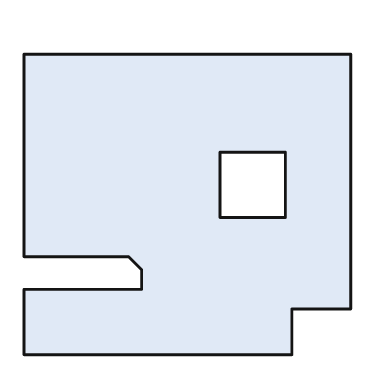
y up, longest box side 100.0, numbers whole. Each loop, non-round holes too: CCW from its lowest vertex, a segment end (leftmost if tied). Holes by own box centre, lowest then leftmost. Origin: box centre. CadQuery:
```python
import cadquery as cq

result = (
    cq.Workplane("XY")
    .moveTo(-50.0, -46.0)
    .lineTo(32.0, -46.0)
    .lineTo(32.0, -32.0)
    .lineTo(50.0, -32.0)
    .lineTo(50.0, 46.0)
    .lineTo(-50.0, 46.0)
    .lineTo(-50.0, -16.0)
    .lineTo(-18.0, -16.0)
    .lineTo(-14.0, -20.0)
    .lineTo(-14.0, -26.0)
    .lineTo(-50.0, -26.0)
    .close()
    .moveTo(10.0, -4.0)
    .lineTo(30.0, -4.0)
    .lineTo(30.0, 16.0)
    .lineTo(10.0, 16.0)
    .close()
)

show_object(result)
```